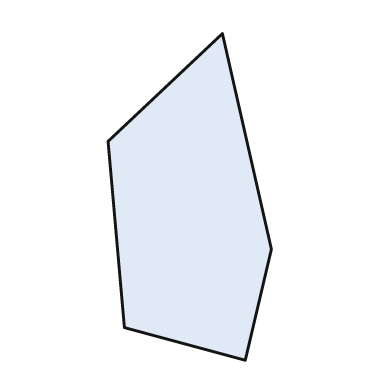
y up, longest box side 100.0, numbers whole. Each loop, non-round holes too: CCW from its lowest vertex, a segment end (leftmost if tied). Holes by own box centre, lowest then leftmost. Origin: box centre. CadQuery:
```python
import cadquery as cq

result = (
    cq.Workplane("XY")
    .moveTo(17.0, -50.0)
    .lineTo(25.0, -16.0)
    .lineTo(10.0, 50.0)
    .lineTo(-25.0, 17.0)
    .lineTo(-20.0, -40.0)
    .close()
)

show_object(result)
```